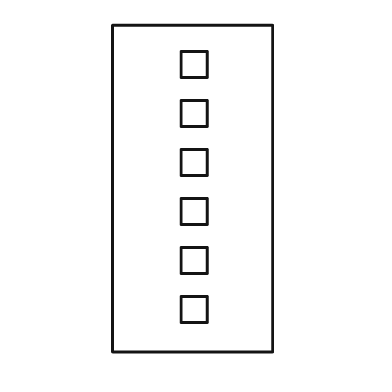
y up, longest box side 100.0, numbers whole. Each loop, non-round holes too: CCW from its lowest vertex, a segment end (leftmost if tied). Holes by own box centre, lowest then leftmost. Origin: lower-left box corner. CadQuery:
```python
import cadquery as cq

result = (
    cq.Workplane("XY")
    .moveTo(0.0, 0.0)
    .lineTo(49.0, 0.0)
    .lineTo(49.0, 100.0)
    .lineTo(0.0, 100.0)
    .close()
    .moveTo(21.0, 9.0)
    .lineTo(29.0, 9.0)
    .lineTo(29.0, 17.0)
    .lineTo(21.0, 17.0)
    .close()
    .moveTo(21.0, 24.0)
    .lineTo(29.0, 24.0)
    .lineTo(29.0, 32.0)
    .lineTo(21.0, 32.0)
    .close()
    .moveTo(21.0, 39.0)
    .lineTo(29.0, 39.0)
    .lineTo(29.0, 47.0)
    .lineTo(21.0, 47.0)
    .close()
    .moveTo(21.0, 54.0)
    .lineTo(29.0, 54.0)
    .lineTo(29.0, 62.0)
    .lineTo(21.0, 62.0)
    .close()
    .moveTo(21.0, 69.0)
    .lineTo(29.0, 69.0)
    .lineTo(29.0, 77.0)
    .lineTo(21.0, 77.0)
    .close()
    .moveTo(21.0, 84.0)
    .lineTo(29.0, 84.0)
    .lineTo(29.0, 92.0)
    .lineTo(21.0, 92.0)
    .close()
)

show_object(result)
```